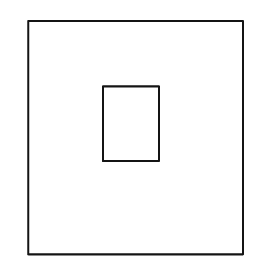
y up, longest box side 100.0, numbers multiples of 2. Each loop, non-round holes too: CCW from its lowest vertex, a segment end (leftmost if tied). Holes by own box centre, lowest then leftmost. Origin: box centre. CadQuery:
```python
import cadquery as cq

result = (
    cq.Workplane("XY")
    .moveTo(-46.0, -50.0)
    .lineTo(46.0, -50.0)
    .lineTo(46.0, 50.0)
    .lineTo(-46.0, 50.0)
    .close()
    .moveTo(-14.0, -10.0)
    .lineTo(10.0, -10.0)
    .lineTo(10.0, 22.0)
    .lineTo(-14.0, 22.0)
    .close()
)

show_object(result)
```